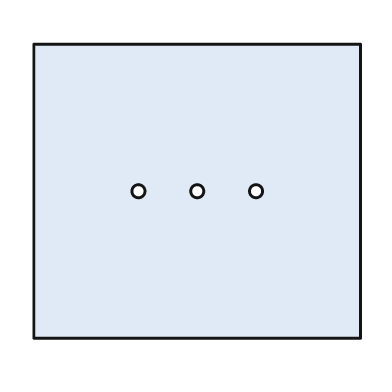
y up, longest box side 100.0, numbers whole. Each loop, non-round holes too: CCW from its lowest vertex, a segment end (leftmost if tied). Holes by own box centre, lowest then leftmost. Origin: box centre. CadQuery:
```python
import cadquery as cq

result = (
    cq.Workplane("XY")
    .moveTo(-50.0, -45.0)
    .lineTo(50.0, -45.0)
    .lineTo(50.0, 45.0)
    .lineTo(-50.0, 45.0)
    .close()
    .moveTo(-18.0, 0.0)
    .circle(2.0)
    .moveTo(0.0, 0.0)
    .circle(2.0)
    .moveTo(18.0, 0.0)
    .circle(2.0)
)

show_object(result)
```